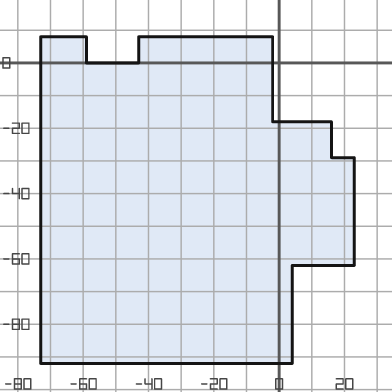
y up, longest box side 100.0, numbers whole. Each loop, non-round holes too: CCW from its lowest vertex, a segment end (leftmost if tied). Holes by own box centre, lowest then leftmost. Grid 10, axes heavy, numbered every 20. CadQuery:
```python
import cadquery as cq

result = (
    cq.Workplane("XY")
    .moveTo(-73.0, -92.0)
    .lineTo(4.0, -92.0)
    .lineTo(4.0, -62.0)
    .lineTo(23.0, -62.0)
    .lineTo(23.0, -29.0)
    .lineTo(16.0, -29.0)
    .lineTo(16.0, -18.0)
    .lineTo(-2.0, -18.0)
    .lineTo(-2.0, 8.0)
    .lineTo(-43.0, 8.0)
    .lineTo(-43.0, 0.0)
    .lineTo(-59.0, 0.0)
    .lineTo(-59.0, 8.0)
    .lineTo(-73.0, 8.0)
    .close()
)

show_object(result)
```